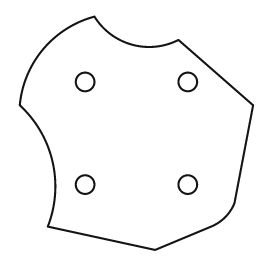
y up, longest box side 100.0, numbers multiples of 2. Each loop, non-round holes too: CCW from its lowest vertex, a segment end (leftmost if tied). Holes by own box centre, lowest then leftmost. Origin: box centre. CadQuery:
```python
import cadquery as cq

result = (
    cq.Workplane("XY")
    .moveTo(8.0, -50.0)
    .lineTo(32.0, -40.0)
    .threePointArc((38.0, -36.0), (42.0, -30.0))
    .lineTo(50.0, 12.0)
    .lineTo(18.0, 40.0)
    .threePointArc((-2.0, 38.0), (-18.0, 50.0))
    .threePointArc((-40.0, 36.0), (-50.0, 12.0))
    .threePointArc((-36.0, -12.0), (-38.0, -40.0))
    .close()
    .moveTo(-22.0, -22.0)
    .circle(4.0)
    .moveTo(22.0, -22.0)
    .circle(4.0)
    .moveTo(-22.0, 22.0)
    .circle(4.0)
    .moveTo(22.0, 22.0)
    .circle(4.0)
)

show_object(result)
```